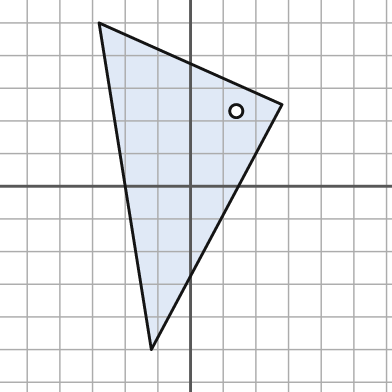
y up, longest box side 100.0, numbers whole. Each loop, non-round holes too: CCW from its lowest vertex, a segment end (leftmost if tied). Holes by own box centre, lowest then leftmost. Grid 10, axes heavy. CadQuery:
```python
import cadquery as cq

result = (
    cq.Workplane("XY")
    .moveTo(-12.0, -50.0)
    .lineTo(28.0, 25.0)
    .lineTo(-28.0, 50.0)
    .close()
    .moveTo(14.0, 23.0)
    .circle(2.0)
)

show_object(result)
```